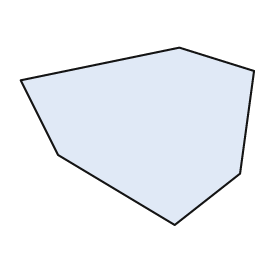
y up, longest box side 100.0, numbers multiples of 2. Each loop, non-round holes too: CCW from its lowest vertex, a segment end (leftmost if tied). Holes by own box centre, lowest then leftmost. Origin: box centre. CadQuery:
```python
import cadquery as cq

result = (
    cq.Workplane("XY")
    .moveTo(16.0, -38.0)
    .lineTo(44.0, -16.0)
    .lineTo(50.0, 28.0)
    .lineTo(18.0, 38.0)
    .lineTo(-50.0, 24.0)
    .lineTo(-34.0, -8.0)
    .close()
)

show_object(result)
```